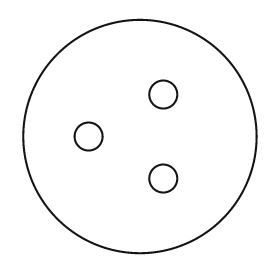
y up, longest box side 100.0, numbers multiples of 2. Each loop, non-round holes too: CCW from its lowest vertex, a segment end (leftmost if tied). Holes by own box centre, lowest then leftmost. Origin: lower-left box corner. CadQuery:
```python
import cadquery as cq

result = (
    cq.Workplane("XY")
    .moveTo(50.0, 50.0)
    .circle(50.0)
    .moveTo(60.0, 32.0)
    .circle(6.0)
    .moveTo(28.0, 50.0)
    .circle(6.0)
    .moveTo(60.0, 68.0)
    .circle(6.0)
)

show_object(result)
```